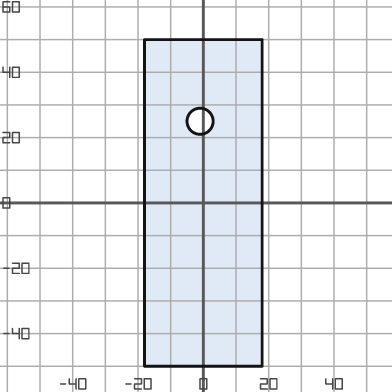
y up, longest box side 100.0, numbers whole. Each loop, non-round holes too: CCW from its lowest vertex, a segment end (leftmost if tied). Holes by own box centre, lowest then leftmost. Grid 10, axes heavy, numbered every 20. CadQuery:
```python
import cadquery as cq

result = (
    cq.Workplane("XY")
    .moveTo(-18.0, -50.0)
    .lineTo(18.0, -50.0)
    .lineTo(18.0, 50.0)
    .lineTo(-18.0, 50.0)
    .close()
    .moveTo(-1.0, 25.0)
    .circle(4.0)
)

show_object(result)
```